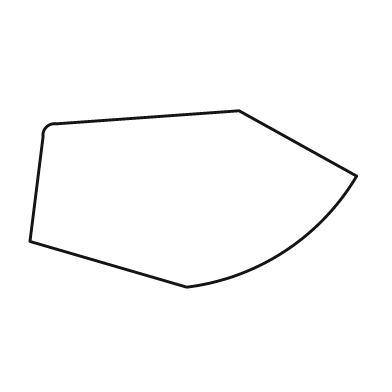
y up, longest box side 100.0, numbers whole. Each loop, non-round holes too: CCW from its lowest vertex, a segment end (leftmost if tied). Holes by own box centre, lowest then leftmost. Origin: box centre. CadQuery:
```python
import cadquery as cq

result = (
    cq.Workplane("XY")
    .moveTo(-2.0, -27.0)
    .threePointArc((28.0, -16.0), (50.0, 7.0))
    .lineTo(14.0, 27.0)
    .lineTo(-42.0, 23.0)
    .threePointArc((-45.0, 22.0), (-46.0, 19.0))
    .lineTo(-50.0, -13.0)
    .close()
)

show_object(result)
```